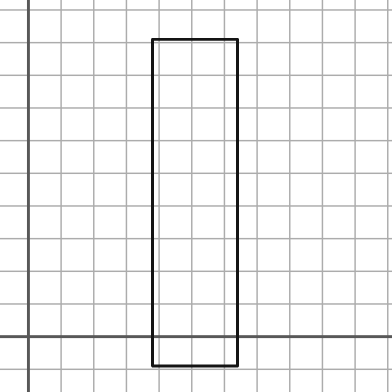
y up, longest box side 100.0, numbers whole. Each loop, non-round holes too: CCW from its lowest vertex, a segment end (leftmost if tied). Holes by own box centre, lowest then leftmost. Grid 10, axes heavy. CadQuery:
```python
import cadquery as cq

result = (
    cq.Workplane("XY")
    .moveTo(38.0, -9.0)
    .lineTo(64.0, -9.0)
    .lineTo(64.0, 91.0)
    .lineTo(38.0, 91.0)
    .close()
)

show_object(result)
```